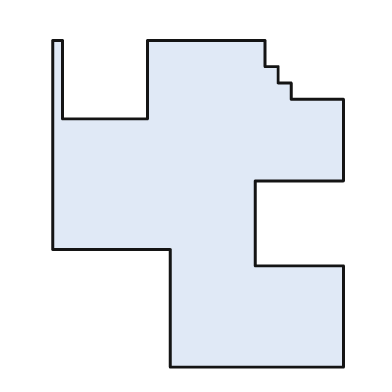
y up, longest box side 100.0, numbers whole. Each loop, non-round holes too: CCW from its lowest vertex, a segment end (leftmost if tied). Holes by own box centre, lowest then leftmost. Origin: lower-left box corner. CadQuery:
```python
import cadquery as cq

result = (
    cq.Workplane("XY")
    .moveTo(36.0, 0.0)
    .lineTo(89.0, 0.0)
    .lineTo(89.0, 31.0)
    .lineTo(62.0, 31.0)
    .lineTo(62.0, 57.0)
    .lineTo(89.0, 57.0)
    .lineTo(89.0, 82.0)
    .lineTo(73.0, 82.0)
    .lineTo(73.0, 87.0)
    .lineTo(69.0, 87.0)
    .lineTo(69.0, 92.0)
    .lineTo(65.0, 92.0)
    .lineTo(65.0, 100.0)
    .lineTo(29.0, 100.0)
    .lineTo(29.0, 76.0)
    .lineTo(3.0, 76.0)
    .lineTo(3.0, 100.0)
    .lineTo(0.0, 100.0)
    .lineTo(0.0, 36.0)
    .lineTo(36.0, 36.0)
    .close()
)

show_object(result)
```